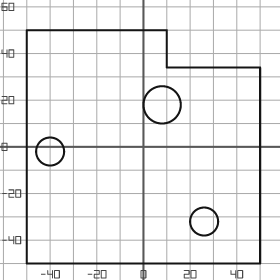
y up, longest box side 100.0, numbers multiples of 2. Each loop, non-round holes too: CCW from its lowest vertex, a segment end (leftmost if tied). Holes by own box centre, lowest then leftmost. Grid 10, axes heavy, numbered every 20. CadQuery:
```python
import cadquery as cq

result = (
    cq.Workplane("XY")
    .moveTo(-50.0, -50.0)
    .lineTo(50.0, -50.0)
    .lineTo(50.0, 34.0)
    .lineTo(10.0, 34.0)
    .lineTo(10.0, 50.0)
    .lineTo(-50.0, 50.0)
    .close()
    .moveTo(26.0, -32.0)
    .circle(6.0)
    .moveTo(-40.0, -2.0)
    .circle(6.0)
    .moveTo(8.0, 18.0)
    .circle(8.0)
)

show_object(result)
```